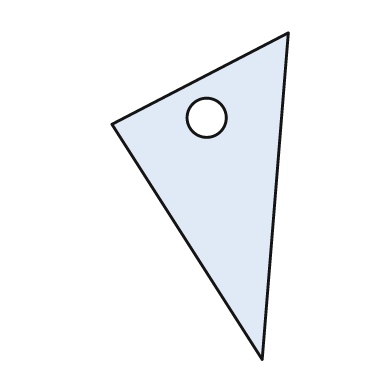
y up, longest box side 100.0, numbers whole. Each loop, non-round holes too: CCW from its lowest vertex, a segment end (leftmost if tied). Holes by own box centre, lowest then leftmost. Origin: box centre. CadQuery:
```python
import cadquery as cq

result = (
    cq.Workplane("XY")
    .moveTo(19.0, -50.0)
    .lineTo(27.0, 50.0)
    .lineTo(-27.0, 22.0)
    .close()
    .moveTo(2.0, 24.0)
    .circle(6.0)
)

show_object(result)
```